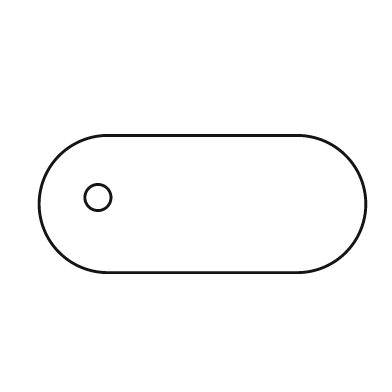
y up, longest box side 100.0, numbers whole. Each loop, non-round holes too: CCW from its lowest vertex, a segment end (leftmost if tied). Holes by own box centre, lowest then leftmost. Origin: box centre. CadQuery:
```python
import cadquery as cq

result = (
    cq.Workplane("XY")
    .moveTo(-29.0, -21.0)
    .lineTo(29.0, -21.0)
    .threePointArc((50.0, 0.0), (29.0, 21.0))
    .lineTo(-29.0, 21.0)
    .threePointArc((-50.0, 0.0), (-29.0, -21.0))
    .close()
    .moveTo(-32.0, 2.0)
    .circle(4.0)
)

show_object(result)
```